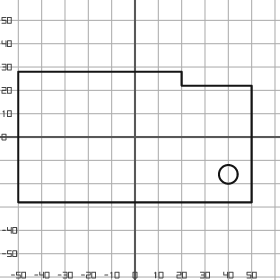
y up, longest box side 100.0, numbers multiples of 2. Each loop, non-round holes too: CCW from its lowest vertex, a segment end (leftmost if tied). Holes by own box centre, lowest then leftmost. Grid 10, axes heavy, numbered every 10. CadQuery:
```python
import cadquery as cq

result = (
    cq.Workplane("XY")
    .moveTo(-50.0, -28.0)
    .lineTo(50.0, -28.0)
    .lineTo(50.0, 22.0)
    .lineTo(20.0, 22.0)
    .lineTo(20.0, 28.0)
    .lineTo(-50.0, 28.0)
    .close()
    .moveTo(40.0, -16.0)
    .circle(4.0)
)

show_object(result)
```